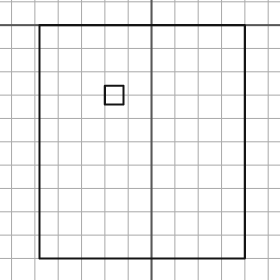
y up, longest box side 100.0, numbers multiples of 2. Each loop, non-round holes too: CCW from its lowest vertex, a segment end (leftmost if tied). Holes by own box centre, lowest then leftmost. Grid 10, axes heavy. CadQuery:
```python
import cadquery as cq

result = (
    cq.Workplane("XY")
    .moveTo(-48.0, -100.0)
    .lineTo(40.0, -100.0)
    .lineTo(40.0, 0.0)
    .lineTo(-48.0, 0.0)
    .close()
    .moveTo(-20.0, -34.0)
    .lineTo(-12.0, -34.0)
    .lineTo(-12.0, -26.0)
    .lineTo(-20.0, -26.0)
    .close()
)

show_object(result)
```